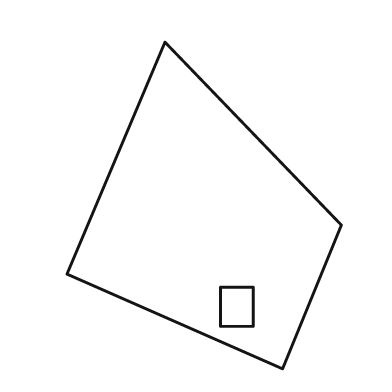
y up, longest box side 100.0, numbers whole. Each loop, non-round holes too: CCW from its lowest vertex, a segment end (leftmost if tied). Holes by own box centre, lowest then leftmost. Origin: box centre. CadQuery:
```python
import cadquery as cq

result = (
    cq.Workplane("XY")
    .moveTo(24.0, -50.0)
    .lineTo(42.0, -6.0)
    .lineTo(-12.0, 50.0)
    .lineTo(-42.0, -21.0)
    .close()
    .moveTo(5.0, -37.0)
    .lineTo(15.0, -37.0)
    .lineTo(15.0, -25.0)
    .lineTo(5.0, -25.0)
    .close()
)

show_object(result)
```